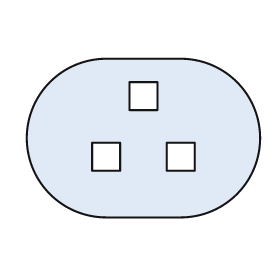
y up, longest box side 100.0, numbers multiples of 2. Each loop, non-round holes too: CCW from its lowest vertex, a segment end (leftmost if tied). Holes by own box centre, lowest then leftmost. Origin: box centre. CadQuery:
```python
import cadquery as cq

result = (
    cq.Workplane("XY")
    .moveTo(-16.0, -34.0)
    .lineTo(16.0, -34.0)
    .threePointArc((50.0, 0.0), (16.0, 34.0))
    .lineTo(-16.0, 34.0)
    .threePointArc((-50.0, 0.0), (-16.0, -34.0))
    .close()
    .moveTo(-22.0, -14.0)
    .lineTo(-10.0, -14.0)
    .lineTo(-10.0, -2.0)
    .lineTo(-22.0, -2.0)
    .close()
    .moveTo(10.0, -14.0)
    .lineTo(22.0, -14.0)
    .lineTo(22.0, -2.0)
    .lineTo(10.0, -2.0)
    .close()
    .moveTo(-6.0, 12.0)
    .lineTo(6.0, 12.0)
    .lineTo(6.0, 24.0)
    .lineTo(-6.0, 24.0)
    .close()
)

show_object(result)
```